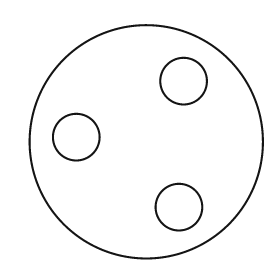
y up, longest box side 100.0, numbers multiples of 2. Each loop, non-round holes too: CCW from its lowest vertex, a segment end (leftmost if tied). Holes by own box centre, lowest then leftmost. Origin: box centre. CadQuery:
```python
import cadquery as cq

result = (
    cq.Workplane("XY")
    .moveTo(0.0, 0.0)
    .circle(50.0)
    .moveTo(14.0, -28.0)
    .circle(10.0)
    .moveTo(-30.0, 2.0)
    .circle(10.0)
    .moveTo(16.0, 26.0)
    .circle(10.0)
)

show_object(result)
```